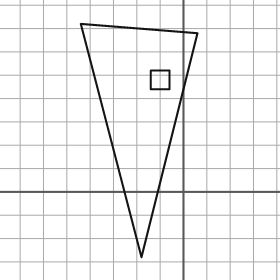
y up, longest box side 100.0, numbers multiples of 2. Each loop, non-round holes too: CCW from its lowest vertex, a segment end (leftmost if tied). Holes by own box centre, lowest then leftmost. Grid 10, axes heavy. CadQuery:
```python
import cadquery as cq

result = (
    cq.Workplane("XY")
    .moveTo(-18.0, -28.0)
    .lineTo(6.0, 68.0)
    .lineTo(-44.0, 72.0)
    .close()
    .moveTo(-14.0, 44.0)
    .lineTo(-6.0, 44.0)
    .lineTo(-6.0, 52.0)
    .lineTo(-14.0, 52.0)
    .close()
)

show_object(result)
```